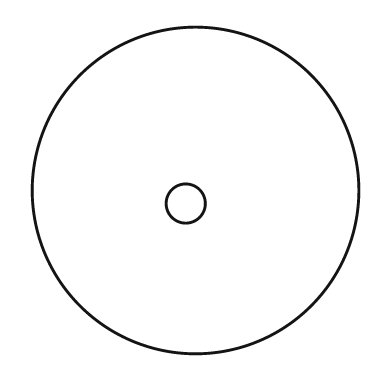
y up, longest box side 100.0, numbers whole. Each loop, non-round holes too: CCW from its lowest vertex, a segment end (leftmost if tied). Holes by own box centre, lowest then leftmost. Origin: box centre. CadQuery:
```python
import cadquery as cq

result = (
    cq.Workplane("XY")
    .moveTo(0.0, 0.0)
    .circle(50.0)
    .moveTo(-3.0, -4.0)
    .circle(6.0)
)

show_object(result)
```